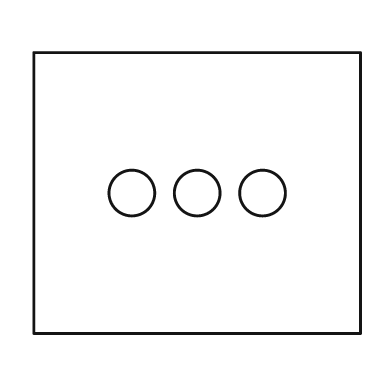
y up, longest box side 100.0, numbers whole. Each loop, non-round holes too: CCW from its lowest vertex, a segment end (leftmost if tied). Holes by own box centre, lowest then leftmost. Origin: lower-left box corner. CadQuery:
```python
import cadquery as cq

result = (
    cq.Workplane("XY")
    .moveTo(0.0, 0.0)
    .lineTo(100.0, 0.0)
    .lineTo(100.0, 86.0)
    .lineTo(0.0, 86.0)
    .close()
    .moveTo(30.0, 43.0)
    .circle(7.0)
    .moveTo(50.0, 43.0)
    .circle(7.0)
    .moveTo(70.0, 43.0)
    .circle(7.0)
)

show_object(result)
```